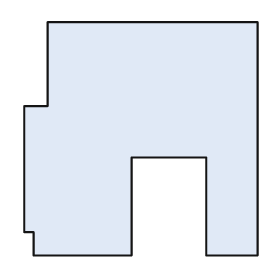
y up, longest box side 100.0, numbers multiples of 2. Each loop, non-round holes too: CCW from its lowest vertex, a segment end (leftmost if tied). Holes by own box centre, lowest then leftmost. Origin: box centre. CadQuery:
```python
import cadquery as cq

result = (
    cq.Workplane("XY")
    .moveTo(-46.0, -50.0)
    .lineTo(-4.0, -50.0)
    .lineTo(-4.0, -8.0)
    .lineTo(28.0, -8.0)
    .lineTo(28.0, -50.0)
    .lineTo(50.0, -50.0)
    .lineTo(50.0, 50.0)
    .lineTo(-40.0, 50.0)
    .lineTo(-40.0, 14.0)
    .lineTo(-50.0, 14.0)
    .lineTo(-50.0, -40.0)
    .lineTo(-46.0, -40.0)
    .close()
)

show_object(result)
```